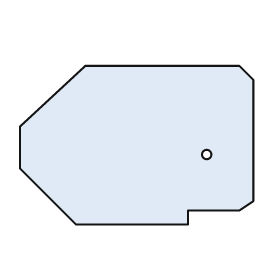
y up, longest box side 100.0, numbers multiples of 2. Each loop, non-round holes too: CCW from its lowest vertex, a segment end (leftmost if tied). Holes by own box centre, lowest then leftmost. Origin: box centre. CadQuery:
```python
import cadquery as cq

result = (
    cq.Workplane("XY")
    .moveTo(-26.0, -34.0)
    .lineTo(22.0, -34.0)
    .lineTo(22.0, -28.0)
    .lineTo(44.0, -28.0)
    .lineTo(50.0, -24.0)
    .lineTo(50.0, 28.0)
    .lineTo(44.0, 34.0)
    .lineTo(-22.0, 34.0)
    .lineTo(-50.0, 8.0)
    .lineTo(-50.0, -10.0)
    .close()
    .moveTo(30.0, -4.0)
    .circle(2.0)
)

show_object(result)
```